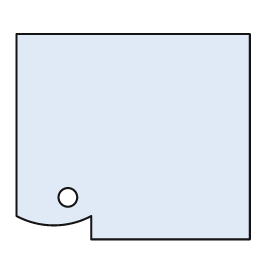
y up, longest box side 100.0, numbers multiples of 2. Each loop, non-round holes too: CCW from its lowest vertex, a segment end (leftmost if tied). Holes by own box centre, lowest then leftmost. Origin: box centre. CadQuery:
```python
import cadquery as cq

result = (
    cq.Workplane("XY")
    .moveTo(-18.0, -44.0)
    .lineTo(50.0, -44.0)
    .lineTo(50.0, 44.0)
    .lineTo(-50.0, 44.0)
    .lineTo(-50.0, -34.0)
    .threePointArc((-34.0, -38.0), (-18.0, -34.0))
    .close()
    .moveTo(-28.0, -26.0)
    .circle(4.0)
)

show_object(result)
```